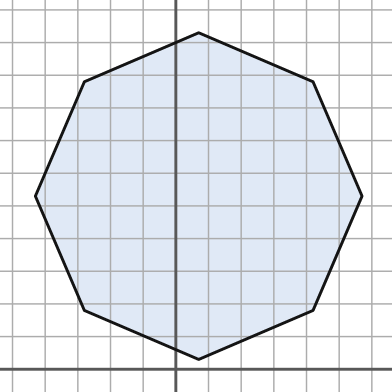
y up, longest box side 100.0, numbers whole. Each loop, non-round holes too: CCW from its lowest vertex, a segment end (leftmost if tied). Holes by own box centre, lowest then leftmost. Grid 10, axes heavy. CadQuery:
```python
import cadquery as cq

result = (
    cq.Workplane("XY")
    .moveTo(7.0, 3.0)
    .lineTo(42.0, 18.0)
    .lineTo(57.0, 53.0)
    .lineTo(42.0, 88.0)
    .lineTo(7.0, 103.0)
    .lineTo(-28.0, 88.0)
    .lineTo(-43.0, 53.0)
    .lineTo(-28.0, 18.0)
    .close()
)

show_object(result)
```